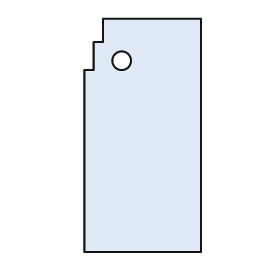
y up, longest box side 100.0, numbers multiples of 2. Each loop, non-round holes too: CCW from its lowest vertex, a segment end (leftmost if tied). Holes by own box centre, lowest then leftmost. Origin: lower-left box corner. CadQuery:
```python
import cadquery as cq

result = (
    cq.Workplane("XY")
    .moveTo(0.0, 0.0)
    .lineTo(50.0, 0.0)
    .lineTo(50.0, 100.0)
    .lineTo(8.0, 100.0)
    .lineTo(8.0, 90.0)
    .lineTo(4.0, 90.0)
    .lineTo(4.0, 78.0)
    .lineTo(0.0, 78.0)
    .close()
    .moveTo(16.0, 82.0)
    .circle(4.0)
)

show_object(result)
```